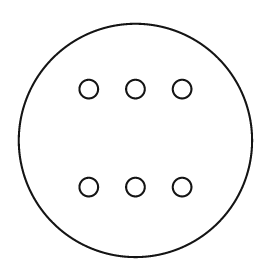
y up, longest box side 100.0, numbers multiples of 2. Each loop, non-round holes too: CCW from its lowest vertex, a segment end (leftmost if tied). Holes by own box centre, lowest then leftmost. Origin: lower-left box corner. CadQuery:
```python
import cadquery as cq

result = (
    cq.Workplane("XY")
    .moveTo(50.0, 50.0)
    .circle(50.0)
    .moveTo(30.0, 30.0)
    .circle(4.0)
    .moveTo(50.0, 30.0)
    .circle(4.0)
    .moveTo(70.0, 30.0)
    .circle(4.0)
    .moveTo(30.0, 72.0)
    .circle(4.0)
    .moveTo(50.0, 72.0)
    .circle(4.0)
    .moveTo(70.0, 72.0)
    .circle(4.0)
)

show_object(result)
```